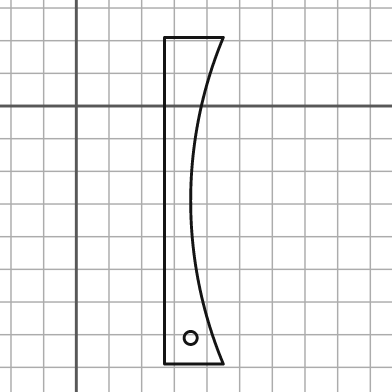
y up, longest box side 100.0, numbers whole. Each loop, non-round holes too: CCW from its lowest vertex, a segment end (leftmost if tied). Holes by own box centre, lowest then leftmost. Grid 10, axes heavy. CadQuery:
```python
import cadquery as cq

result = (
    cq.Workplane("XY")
    .moveTo(27.0, -79.0)
    .lineTo(45.0, -79.0)
    .threePointArc((35.0, -29.0), (45.0, 21.0))
    .lineTo(27.0, 21.0)
    .close()
    .moveTo(35.0, -71.0)
    .circle(2.0)
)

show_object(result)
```